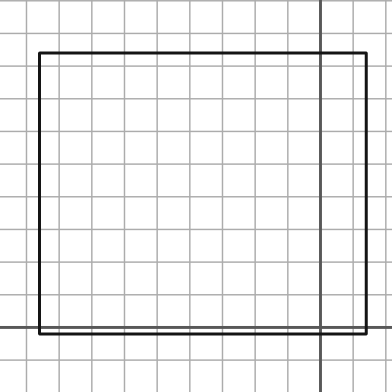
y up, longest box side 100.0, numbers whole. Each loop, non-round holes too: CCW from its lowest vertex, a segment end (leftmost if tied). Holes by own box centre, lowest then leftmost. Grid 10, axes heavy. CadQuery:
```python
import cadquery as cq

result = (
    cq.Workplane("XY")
    .moveTo(-86.0, -2.0)
    .lineTo(14.0, -2.0)
    .lineTo(14.0, 84.0)
    .lineTo(-86.0, 84.0)
    .close()
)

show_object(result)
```